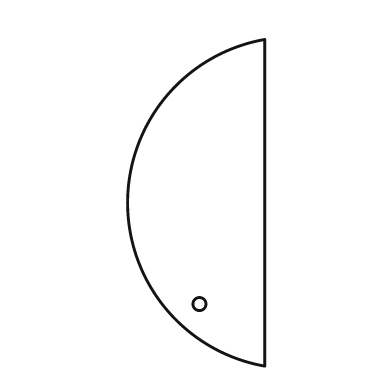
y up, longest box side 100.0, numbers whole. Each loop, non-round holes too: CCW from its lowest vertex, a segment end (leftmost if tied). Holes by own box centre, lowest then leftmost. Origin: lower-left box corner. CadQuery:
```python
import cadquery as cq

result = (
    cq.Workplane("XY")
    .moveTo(42.0, 0.0)
    .lineTo(42.0, 100.0)
    .threePointArc((0.0, 50.0), (42.0, 0.0))
    .close()
    .moveTo(22.0, 19.0)
    .circle(2.0)
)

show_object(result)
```